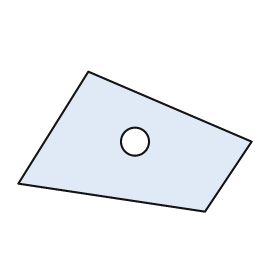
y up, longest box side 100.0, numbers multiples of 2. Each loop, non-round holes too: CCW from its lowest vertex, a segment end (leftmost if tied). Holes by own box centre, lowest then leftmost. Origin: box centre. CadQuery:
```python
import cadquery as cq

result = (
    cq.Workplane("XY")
    .moveTo(30.0, -30.0)
    .lineTo(50.0, 0.0)
    .lineTo(-20.0, 30.0)
    .lineTo(-50.0, -18.0)
    .close()
    .moveTo(0.0, 0.0)
    .circle(6.0)
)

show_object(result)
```